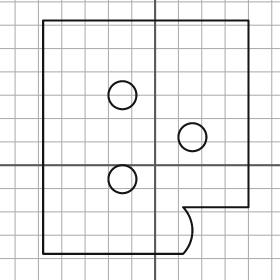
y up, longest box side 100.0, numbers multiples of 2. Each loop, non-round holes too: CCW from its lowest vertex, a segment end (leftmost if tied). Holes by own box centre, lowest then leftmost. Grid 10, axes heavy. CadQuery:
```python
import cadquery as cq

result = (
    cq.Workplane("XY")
    .moveTo(-48.0, -38.0)
    .lineTo(12.0, -38.0)
    .threePointArc((16.0, -28.0), (12.0, -18.0))
    .lineTo(40.0, -18.0)
    .lineTo(40.0, 62.0)
    .lineTo(-48.0, 62.0)
    .close()
    .moveTo(-14.0, -6.0)
    .circle(6.0)
    .moveTo(16.0, 12.0)
    .circle(6.0)
    .moveTo(-14.0, 30.0)
    .circle(6.0)
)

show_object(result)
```